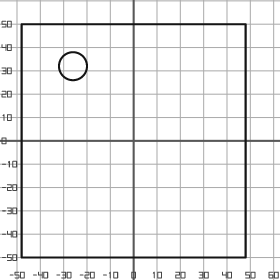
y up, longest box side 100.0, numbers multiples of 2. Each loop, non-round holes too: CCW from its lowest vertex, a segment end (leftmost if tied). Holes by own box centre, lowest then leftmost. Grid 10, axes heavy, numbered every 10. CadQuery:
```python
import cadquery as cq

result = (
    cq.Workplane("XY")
    .moveTo(-48.0, -50.0)
    .lineTo(48.0, -50.0)
    .lineTo(48.0, 50.0)
    .lineTo(-48.0, 50.0)
    .close()
    .moveTo(-26.0, 32.0)
    .circle(6.0)
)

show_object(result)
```